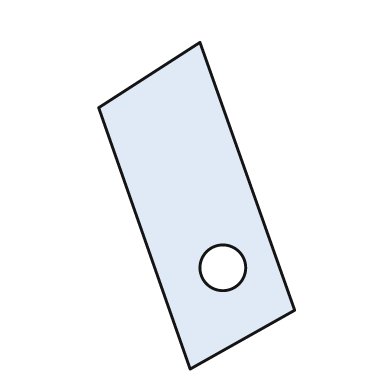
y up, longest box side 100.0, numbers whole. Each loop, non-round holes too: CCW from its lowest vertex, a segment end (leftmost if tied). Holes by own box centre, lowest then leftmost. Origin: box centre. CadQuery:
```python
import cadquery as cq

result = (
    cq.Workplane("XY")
    .moveTo(-2.0, -50.0)
    .lineTo(30.0, -32.0)
    .lineTo(1.0, 50.0)
    .lineTo(-30.0, 30.0)
    .close()
    .moveTo(8.0, -19.0)
    .circle(7.0)
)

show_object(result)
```